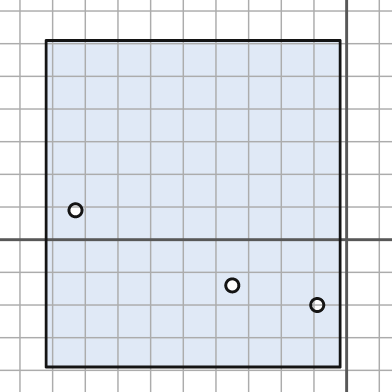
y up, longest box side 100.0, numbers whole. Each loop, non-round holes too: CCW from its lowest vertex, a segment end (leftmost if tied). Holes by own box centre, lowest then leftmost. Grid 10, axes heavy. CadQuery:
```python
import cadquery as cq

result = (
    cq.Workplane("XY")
    .moveTo(-92.0, -39.0)
    .lineTo(-2.0, -39.0)
    .lineTo(-2.0, 61.0)
    .lineTo(-92.0, 61.0)
    .close()
    .moveTo(-9.0, -20.0)
    .circle(2.0)
    .moveTo(-35.0, -14.0)
    .circle(2.0)
    .moveTo(-83.0, 9.0)
    .circle(2.0)
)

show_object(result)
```